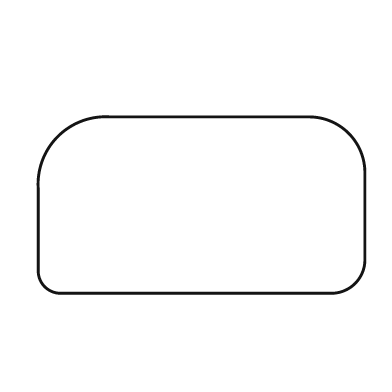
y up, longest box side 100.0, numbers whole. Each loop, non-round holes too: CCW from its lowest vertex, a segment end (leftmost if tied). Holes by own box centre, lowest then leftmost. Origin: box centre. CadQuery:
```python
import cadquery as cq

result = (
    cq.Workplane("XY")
    .moveTo(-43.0, -27.0)
    .lineTo(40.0, -27.0)
    .threePointArc((47.0, -24.0), (50.0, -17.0))
    .lineTo(50.0, 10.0)
    .threePointArc((45.0, 22.0), (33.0, 27.0))
    .lineTo(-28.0, 27.0)
    .threePointArc((-44.0, 21.0), (-50.0, 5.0))
    .lineTo(-50.0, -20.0)
    .threePointArc((-48.0, -25.0), (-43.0, -27.0))
    .close()
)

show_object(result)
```